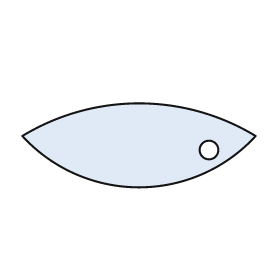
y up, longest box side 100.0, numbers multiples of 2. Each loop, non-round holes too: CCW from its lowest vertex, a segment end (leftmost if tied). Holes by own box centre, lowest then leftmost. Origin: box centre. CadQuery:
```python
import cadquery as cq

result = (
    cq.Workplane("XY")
    .moveTo(-50.0, 4.0)
    .threePointArc((0.0, -18.0), (50.0, 4.0))
    .threePointArc((0.0, 18.0), (-50.0, 4.0))
    .close()
    .moveTo(30.0, -2.0)
    .circle(4.0)
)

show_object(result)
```